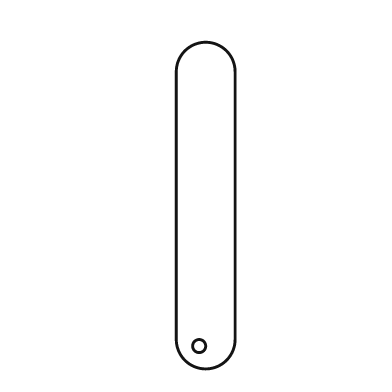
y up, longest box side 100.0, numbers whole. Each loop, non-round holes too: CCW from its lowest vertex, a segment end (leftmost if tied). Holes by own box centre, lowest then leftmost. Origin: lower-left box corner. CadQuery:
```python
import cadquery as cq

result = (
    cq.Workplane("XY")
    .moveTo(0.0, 9.0)
    .threePointArc((9.0, 0.0), (18.0, 9.0))
    .lineTo(18.0, 91.0)
    .threePointArc((9.0, 100.0), (0.0, 91.0))
    .close()
    .moveTo(7.0, 7.0)
    .circle(2.0)
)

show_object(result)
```